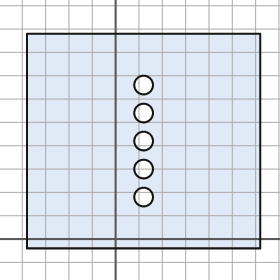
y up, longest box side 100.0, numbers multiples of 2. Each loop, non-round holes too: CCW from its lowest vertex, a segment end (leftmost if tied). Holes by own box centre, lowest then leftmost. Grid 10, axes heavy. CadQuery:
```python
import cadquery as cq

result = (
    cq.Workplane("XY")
    .moveTo(-38.0, -4.0)
    .lineTo(62.0, -4.0)
    .lineTo(62.0, 88.0)
    .lineTo(-38.0, 88.0)
    .close()
    .moveTo(12.0, 18.0)
    .circle(4.0)
    .moveTo(12.0, 30.0)
    .circle(4.0)
    .moveTo(12.0, 42.0)
    .circle(4.0)
    .moveTo(12.0, 54.0)
    .circle(4.0)
    .moveTo(12.0, 66.0)
    .circle(4.0)
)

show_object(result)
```